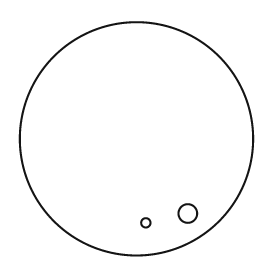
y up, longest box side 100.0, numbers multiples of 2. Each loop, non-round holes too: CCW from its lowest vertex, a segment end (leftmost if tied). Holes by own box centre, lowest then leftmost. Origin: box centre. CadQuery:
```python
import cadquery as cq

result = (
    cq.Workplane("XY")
    .moveTo(0.0, 0.0)
    .circle(50.0)
    .moveTo(4.0, -36.0)
    .circle(2.0)
    .moveTo(22.0, -32.0)
    .circle(4.0)
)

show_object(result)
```